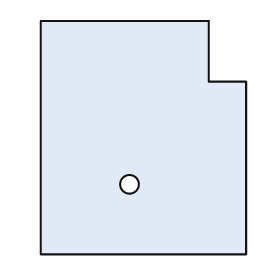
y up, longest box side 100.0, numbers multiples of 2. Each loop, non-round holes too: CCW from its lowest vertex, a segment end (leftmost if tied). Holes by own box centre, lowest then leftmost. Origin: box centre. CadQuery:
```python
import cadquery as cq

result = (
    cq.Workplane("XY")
    .moveTo(-44.0, -50.0)
    .lineTo(44.0, -50.0)
    .lineTo(44.0, 24.0)
    .lineTo(28.0, 24.0)
    .lineTo(28.0, 50.0)
    .lineTo(-44.0, 50.0)
    .close()
    .moveTo(-6.0, -20.0)
    .circle(4.0)
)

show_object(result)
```